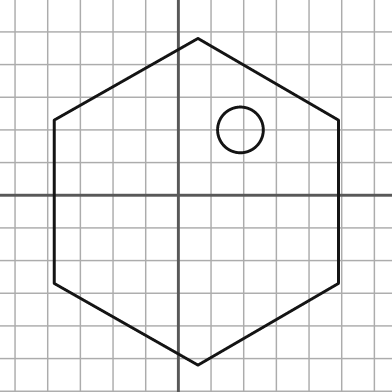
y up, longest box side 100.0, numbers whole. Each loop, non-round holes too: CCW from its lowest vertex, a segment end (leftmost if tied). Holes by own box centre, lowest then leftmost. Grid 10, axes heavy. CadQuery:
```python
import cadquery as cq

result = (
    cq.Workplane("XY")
    .moveTo(6.0, -52.0)
    .lineTo(49.0, -27.0)
    .lineTo(49.0, 23.0)
    .lineTo(6.0, 48.0)
    .lineTo(-38.0, 23.0)
    .lineTo(-38.0, -27.0)
    .close()
    .moveTo(19.0, 20.0)
    .circle(7.0)
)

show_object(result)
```